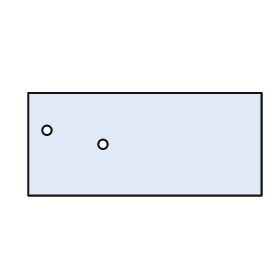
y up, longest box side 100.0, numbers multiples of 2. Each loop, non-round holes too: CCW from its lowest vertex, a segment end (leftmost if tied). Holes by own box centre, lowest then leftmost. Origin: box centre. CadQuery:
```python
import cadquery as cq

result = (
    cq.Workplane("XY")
    .moveTo(-50.0, -22.0)
    .lineTo(50.0, -22.0)
    .lineTo(50.0, 22.0)
    .lineTo(-50.0, 22.0)
    .close()
    .moveTo(-18.0, 0.0)
    .circle(2.0)
    .moveTo(-42.0, 6.0)
    .circle(2.0)
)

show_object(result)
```